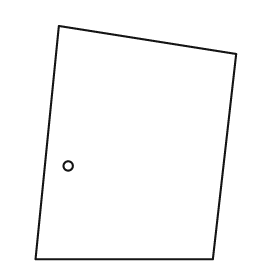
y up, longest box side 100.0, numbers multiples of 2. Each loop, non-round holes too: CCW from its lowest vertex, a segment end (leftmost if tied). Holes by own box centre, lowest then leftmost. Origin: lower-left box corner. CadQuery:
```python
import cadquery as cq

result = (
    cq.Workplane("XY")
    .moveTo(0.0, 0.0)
    .lineTo(76.0, 0.0)
    .lineTo(86.0, 88.0)
    .lineTo(10.0, 100.0)
    .close()
    .moveTo(14.0, 40.0)
    .circle(2.0)
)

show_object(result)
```